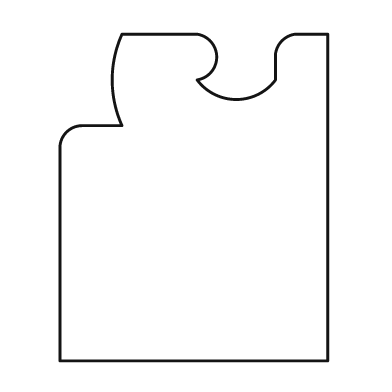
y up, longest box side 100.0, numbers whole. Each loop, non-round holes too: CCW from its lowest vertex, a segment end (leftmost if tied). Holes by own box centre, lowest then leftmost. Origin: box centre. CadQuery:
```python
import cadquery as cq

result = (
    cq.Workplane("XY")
    .moveTo(-41.0, -50.0)
    .lineTo(41.0, -50.0)
    .lineTo(41.0, 50.0)
    .lineTo(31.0, 50.0)
    .threePointArc((27.0, 48.0), (25.0, 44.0))
    .lineTo(25.0, 36.0)
    .threePointArc((13.0, 30.0), (1.0, 36.0))
    .threePointArc((7.0, 43.0), (1.0, 50.0))
    .lineTo(-22.0, 50.0)
    .threePointArc((-25.0, 36.0), (-22.0, 22.0))
    .lineTo(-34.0, 22.0)
    .threePointArc((-39.0, 20.0), (-41.0, 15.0))
    .close()
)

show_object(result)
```